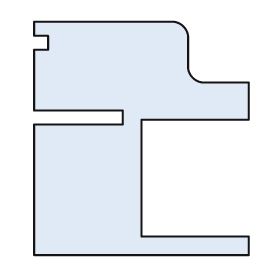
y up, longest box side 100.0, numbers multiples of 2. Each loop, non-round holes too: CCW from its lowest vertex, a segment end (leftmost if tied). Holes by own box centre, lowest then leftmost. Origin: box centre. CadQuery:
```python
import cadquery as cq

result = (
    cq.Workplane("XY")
    .moveTo(-46.0, -50.0)
    .lineTo(46.0, -50.0)
    .lineTo(46.0, -42.0)
    .lineTo(0.0, -42.0)
    .lineTo(0.0, 8.0)
    .lineTo(46.0, 8.0)
    .lineTo(46.0, 24.0)
    .lineTo(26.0, 24.0)
    .threePointArc((22.0, 26.0), (20.0, 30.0))
    .lineTo(20.0, 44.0)
    .threePointArc((18.0, 48.0), (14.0, 50.0))
    .lineTo(-46.0, 50.0)
    .lineTo(-46.0, 44.0)
    .lineTo(-40.0, 44.0)
    .lineTo(-40.0, 38.0)
    .lineTo(-46.0, 38.0)
    .lineTo(-46.0, 12.0)
    .lineTo(-8.0, 12.0)
    .lineTo(-8.0, 6.0)
    .lineTo(-46.0, 6.0)
    .close()
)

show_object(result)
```